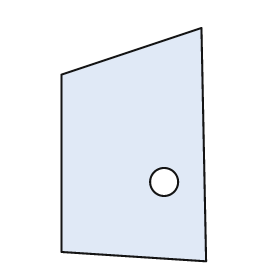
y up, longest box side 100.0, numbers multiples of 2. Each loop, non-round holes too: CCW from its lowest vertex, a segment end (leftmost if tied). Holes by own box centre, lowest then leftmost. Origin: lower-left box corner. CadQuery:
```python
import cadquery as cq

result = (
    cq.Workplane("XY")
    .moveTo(62.0, 0.0)
    .lineTo(60.0, 100.0)
    .lineTo(0.0, 80.0)
    .lineTo(0.0, 4.0)
    .close()
    .moveTo(44.0, 34.0)
    .circle(6.0)
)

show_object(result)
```